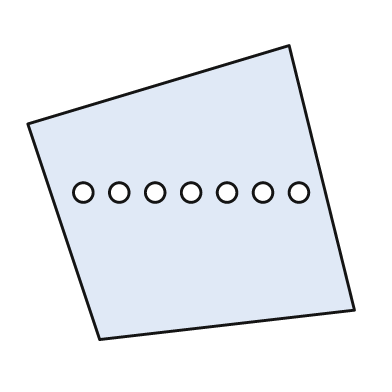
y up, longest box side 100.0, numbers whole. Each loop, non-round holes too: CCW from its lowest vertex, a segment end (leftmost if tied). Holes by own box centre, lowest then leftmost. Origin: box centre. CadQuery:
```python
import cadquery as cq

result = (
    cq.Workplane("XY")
    .moveTo(-28.0, -45.0)
    .lineTo(50.0, -36.0)
    .lineTo(30.0, 45.0)
    .lineTo(-50.0, 21.0)
    .close()
    .moveTo(-33.0, 0.0)
    .circle(3.0)
    .moveTo(-22.0, 0.0)
    .circle(3.0)
    .moveTo(-11.0, 0.0)
    .circle(3.0)
    .moveTo(0.0, 0.0)
    .circle(3.0)
    .moveTo(11.0, 0.0)
    .circle(3.0)
    .moveTo(22.0, 0.0)
    .circle(3.0)
    .moveTo(33.0, 0.0)
    .circle(3.0)
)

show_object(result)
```